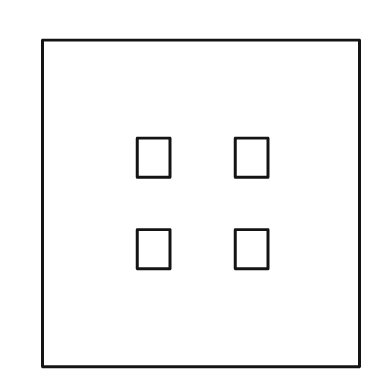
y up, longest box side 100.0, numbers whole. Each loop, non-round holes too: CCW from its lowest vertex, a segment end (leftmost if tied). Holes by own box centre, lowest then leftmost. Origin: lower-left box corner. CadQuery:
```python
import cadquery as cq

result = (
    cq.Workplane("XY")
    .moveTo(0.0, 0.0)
    .lineTo(97.0, 0.0)
    .lineTo(97.0, 100.0)
    .lineTo(0.0, 100.0)
    .close()
    .moveTo(29.0, 30.0)
    .lineTo(39.0, 30.0)
    .lineTo(39.0, 42.0)
    .lineTo(29.0, 42.0)
    .close()
    .moveTo(59.0, 30.0)
    .lineTo(69.0, 30.0)
    .lineTo(69.0, 42.0)
    .lineTo(59.0, 42.0)
    .close()
    .moveTo(29.0, 58.0)
    .lineTo(39.0, 58.0)
    .lineTo(39.0, 70.0)
    .lineTo(29.0, 70.0)
    .close()
    .moveTo(59.0, 58.0)
    .lineTo(69.0, 58.0)
    .lineTo(69.0, 70.0)
    .lineTo(59.0, 70.0)
    .close()
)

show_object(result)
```